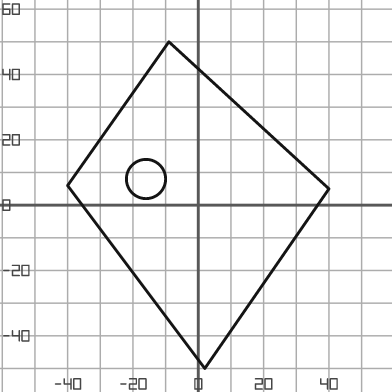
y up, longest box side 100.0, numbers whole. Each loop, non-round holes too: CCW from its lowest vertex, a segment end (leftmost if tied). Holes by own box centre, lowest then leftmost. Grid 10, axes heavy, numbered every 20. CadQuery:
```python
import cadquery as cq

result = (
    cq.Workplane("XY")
    .moveTo(2.0, -50.0)
    .lineTo(40.0, 5.0)
    .lineTo(-9.0, 50.0)
    .lineTo(-40.0, 6.0)
    .close()
    .moveTo(-16.0, 8.0)
    .circle(6.0)
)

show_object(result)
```